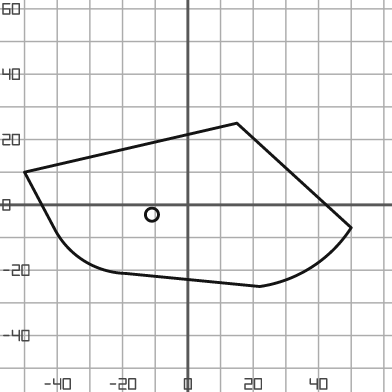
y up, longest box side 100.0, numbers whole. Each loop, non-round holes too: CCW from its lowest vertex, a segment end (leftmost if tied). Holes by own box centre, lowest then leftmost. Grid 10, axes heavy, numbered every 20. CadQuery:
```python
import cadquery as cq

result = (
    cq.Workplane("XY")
    .moveTo(22.0, -25.0)
    .threePointArc((38.0, -19.0), (50.0, -7.0))
    .lineTo(15.0, 25.0)
    .lineTo(-50.0, 10.0)
    .lineTo(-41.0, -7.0)
    .threePointArc((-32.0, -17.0), (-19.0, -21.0))
    .close()
    .moveTo(-11.0, -3.0)
    .circle(2.0)
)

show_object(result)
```